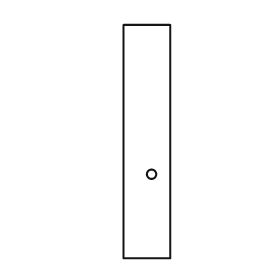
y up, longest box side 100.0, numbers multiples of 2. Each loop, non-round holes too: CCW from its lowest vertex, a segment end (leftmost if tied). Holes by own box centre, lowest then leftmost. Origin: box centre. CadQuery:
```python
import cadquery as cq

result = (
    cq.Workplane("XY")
    .moveTo(-10.0, -50.0)
    .lineTo(10.0, -50.0)
    .lineTo(10.0, 50.0)
    .lineTo(-10.0, 50.0)
    .close()
    .moveTo(2.0, -14.0)
    .circle(2.0)
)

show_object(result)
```